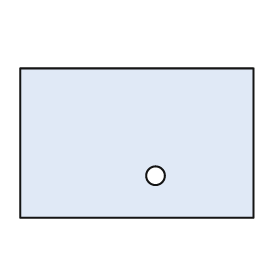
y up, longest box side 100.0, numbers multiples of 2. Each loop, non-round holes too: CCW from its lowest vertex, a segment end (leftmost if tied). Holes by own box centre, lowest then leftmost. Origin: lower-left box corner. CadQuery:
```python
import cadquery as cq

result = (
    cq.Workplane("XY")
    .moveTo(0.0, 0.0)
    .lineTo(100.0, 0.0)
    .lineTo(100.0, 64.0)
    .lineTo(0.0, 64.0)
    .close()
    .moveTo(58.0, 18.0)
    .circle(4.0)
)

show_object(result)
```